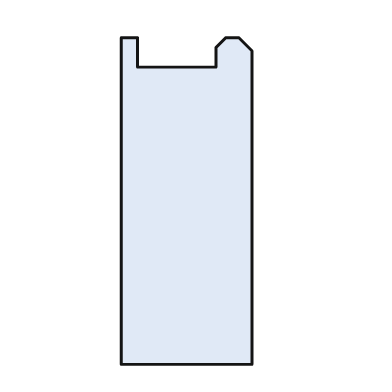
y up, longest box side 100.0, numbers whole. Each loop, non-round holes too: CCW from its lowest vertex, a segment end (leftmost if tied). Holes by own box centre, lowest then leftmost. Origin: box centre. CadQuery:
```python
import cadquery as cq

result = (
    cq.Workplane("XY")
    .moveTo(-20.0, -50.0)
    .lineTo(20.0, -50.0)
    .lineTo(20.0, 46.0)
    .lineTo(16.0, 50.0)
    .lineTo(12.0, 50.0)
    .lineTo(9.0, 47.0)
    .lineTo(9.0, 41.0)
    .lineTo(-15.0, 41.0)
    .lineTo(-15.0, 50.0)
    .lineTo(-20.0, 50.0)
    .close()
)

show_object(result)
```